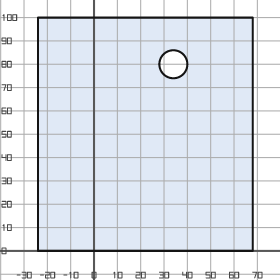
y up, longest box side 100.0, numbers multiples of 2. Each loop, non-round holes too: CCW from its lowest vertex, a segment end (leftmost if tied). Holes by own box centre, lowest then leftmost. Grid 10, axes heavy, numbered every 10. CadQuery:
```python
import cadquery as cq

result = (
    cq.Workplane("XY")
    .moveTo(-24.0, 0.0)
    .lineTo(68.0, 0.0)
    .lineTo(68.0, 100.0)
    .lineTo(-24.0, 100.0)
    .close()
    .moveTo(34.0, 80.0)
    .circle(6.0)
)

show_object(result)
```